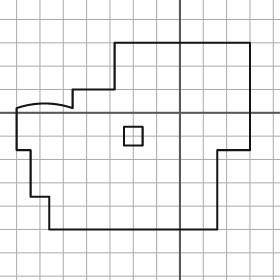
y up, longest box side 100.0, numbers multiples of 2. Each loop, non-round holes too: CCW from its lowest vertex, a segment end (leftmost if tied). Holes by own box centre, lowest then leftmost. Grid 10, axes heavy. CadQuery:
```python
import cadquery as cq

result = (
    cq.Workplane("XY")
    .moveTo(-56.0, -50.0)
    .lineTo(16.0, -50.0)
    .lineTo(16.0, -16.0)
    .lineTo(30.0, -16.0)
    .lineTo(30.0, 30.0)
    .lineTo(-28.0, 30.0)
    .lineTo(-28.0, 10.0)
    .lineTo(-46.0, 10.0)
    .lineTo(-46.0, 2.0)
    .threePointArc((-58.0, 4.0), (-70.0, 2.0))
    .lineTo(-70.0, -16.0)
    .lineTo(-64.0, -16.0)
    .lineTo(-64.0, -36.0)
    .lineTo(-56.0, -36.0)
    .close()
    .moveTo(-24.0, -14.0)
    .lineTo(-16.0, -14.0)
    .lineTo(-16.0, -6.0)
    .lineTo(-24.0, -6.0)
    .close()
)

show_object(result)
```